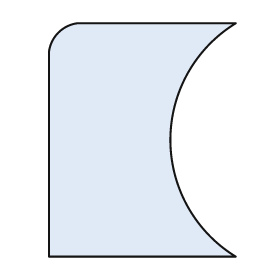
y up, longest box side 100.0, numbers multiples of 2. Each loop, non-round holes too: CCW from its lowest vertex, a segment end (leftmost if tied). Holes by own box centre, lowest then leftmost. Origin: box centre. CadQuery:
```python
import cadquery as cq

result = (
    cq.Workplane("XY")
    .moveTo(-40.0, -50.0)
    .lineTo(40.0, -50.0)
    .threePointArc((12.0, 0.0), (40.0, 50.0))
    .lineTo(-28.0, 50.0)
    .threePointArc((-36.0, 46.0), (-40.0, 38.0))
    .close()
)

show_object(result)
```